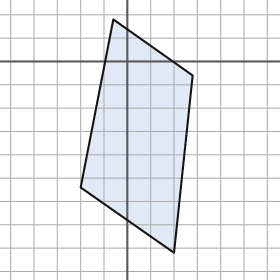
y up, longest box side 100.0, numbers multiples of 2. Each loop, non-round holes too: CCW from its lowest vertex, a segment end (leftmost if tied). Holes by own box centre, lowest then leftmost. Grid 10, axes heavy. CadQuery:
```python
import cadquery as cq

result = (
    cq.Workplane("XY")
    .moveTo(20.0, -82.0)
    .lineTo(28.0, -6.0)
    .lineTo(-6.0, 18.0)
    .lineTo(-20.0, -54.0)
    .close()
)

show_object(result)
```